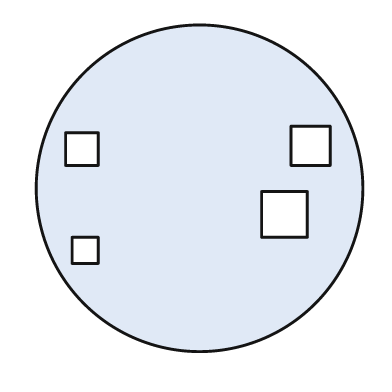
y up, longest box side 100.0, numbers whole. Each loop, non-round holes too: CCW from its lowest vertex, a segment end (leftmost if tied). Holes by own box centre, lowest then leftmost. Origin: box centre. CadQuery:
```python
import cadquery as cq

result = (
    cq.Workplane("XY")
    .moveTo(0.0, 0.0)
    .circle(50.0)
    .moveTo(-39.0, -23.0)
    .lineTo(-31.0, -23.0)
    .lineTo(-31.0, -15.0)
    .lineTo(-39.0, -15.0)
    .close()
    .moveTo(19.0, -15.0)
    .lineTo(33.0, -15.0)
    .lineTo(33.0, -1.0)
    .lineTo(19.0, -1.0)
    .close()
    .moveTo(-41.0, 7.0)
    .lineTo(-31.0, 7.0)
    .lineTo(-31.0, 17.0)
    .lineTo(-41.0, 17.0)
    .close()
    .moveTo(28.0, 7.0)
    .lineTo(40.0, 7.0)
    .lineTo(40.0, 19.0)
    .lineTo(28.0, 19.0)
    .close()
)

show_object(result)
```